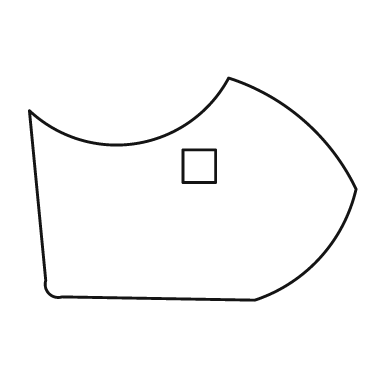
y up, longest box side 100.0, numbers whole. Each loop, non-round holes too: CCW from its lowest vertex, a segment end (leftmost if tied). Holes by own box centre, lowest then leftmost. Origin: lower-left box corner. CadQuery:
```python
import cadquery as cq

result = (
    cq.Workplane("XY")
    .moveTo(69.0, 0.0)
    .threePointArc((89.0, 13.0), (100.0, 34.0))
    .threePointArc((84.0, 55.0), (61.0, 68.0))
    .threePointArc((33.0, 48.0), (0.0, 58.0))
    .lineTo(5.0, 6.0)
    .threePointArc((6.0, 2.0), (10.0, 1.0))
    .close()
    .moveTo(47.0, 36.0)
    .lineTo(57.0, 36.0)
    .lineTo(57.0, 46.0)
    .lineTo(47.0, 46.0)
    .close()
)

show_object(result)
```